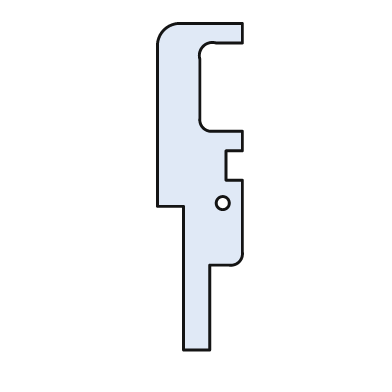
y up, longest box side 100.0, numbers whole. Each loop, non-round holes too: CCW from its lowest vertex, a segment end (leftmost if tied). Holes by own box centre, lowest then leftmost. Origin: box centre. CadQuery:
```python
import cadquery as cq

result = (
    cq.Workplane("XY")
    .moveTo(-5.0, -50.0)
    .lineTo(3.0, -50.0)
    .lineTo(3.0, -24.0)
    .lineTo(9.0, -24.0)
    .threePointArc((12.0, -23.0), (13.0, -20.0))
    .lineTo(13.0, 2.0)
    .lineTo(8.0, 2.0)
    .lineTo(8.0, 11.0)
    .lineTo(13.0, 11.0)
    .lineTo(13.0, 17.0)
    .lineTo(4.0, 17.0)
    .threePointArc((1.0, 18.0), (0.0, 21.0))
    .lineTo(0.0, 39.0)
    .threePointArc((1.0, 43.0), (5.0, 44.0))
    .lineTo(13.0, 44.0)
    .lineTo(13.0, 50.0)
    .lineTo(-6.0, 50.0)
    .threePointArc((-11.0, 48.0), (-13.0, 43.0))
    .lineTo(-13.0, -6.0)
    .lineTo(-5.0, -6.0)
    .close()
    .moveTo(7.0, -5.0)
    .circle(2.0)
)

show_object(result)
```